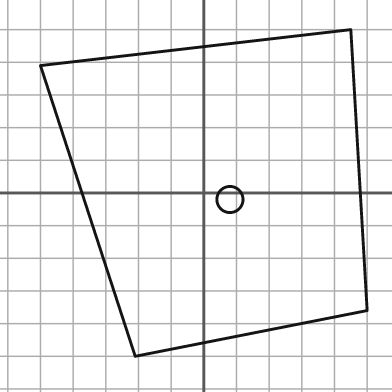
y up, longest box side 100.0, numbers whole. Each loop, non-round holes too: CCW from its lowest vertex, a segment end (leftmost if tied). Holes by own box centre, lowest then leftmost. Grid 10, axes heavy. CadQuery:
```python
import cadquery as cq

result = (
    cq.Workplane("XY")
    .moveTo(-21.0, -50.0)
    .lineTo(50.0, -36.0)
    .lineTo(45.0, 50.0)
    .lineTo(-50.0, 39.0)
    .close()
    .moveTo(8.0, -2.0)
    .circle(4.0)
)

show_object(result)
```